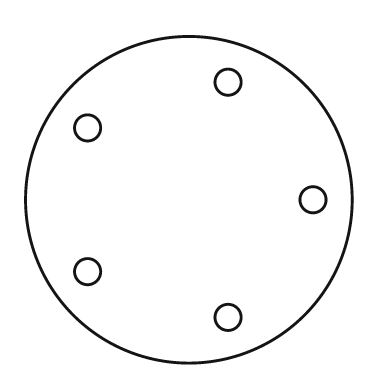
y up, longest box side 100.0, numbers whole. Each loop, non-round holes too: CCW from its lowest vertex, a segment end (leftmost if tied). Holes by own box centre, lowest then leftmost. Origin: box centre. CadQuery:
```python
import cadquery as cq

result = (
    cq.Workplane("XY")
    .moveTo(0.0, 0.0)
    .circle(50.0)
    .moveTo(12.0, -36.0)
    .circle(4.0)
    .moveTo(-31.0, -22.0)
    .circle(4.0)
    .moveTo(38.0, 0.0)
    .circle(4.0)
    .moveTo(-31.0, 22.0)
    .circle(4.0)
    .moveTo(12.0, 36.0)
    .circle(4.0)
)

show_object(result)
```